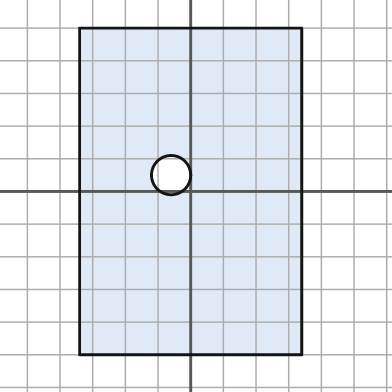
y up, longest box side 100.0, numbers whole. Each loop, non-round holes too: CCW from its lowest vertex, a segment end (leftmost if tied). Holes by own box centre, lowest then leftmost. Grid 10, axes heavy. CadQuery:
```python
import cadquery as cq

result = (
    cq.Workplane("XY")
    .moveTo(-34.0, -50.0)
    .lineTo(34.0, -50.0)
    .lineTo(34.0, 50.0)
    .lineTo(-34.0, 50.0)
    .close()
    .moveTo(-6.0, 5.0)
    .circle(6.0)
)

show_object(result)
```